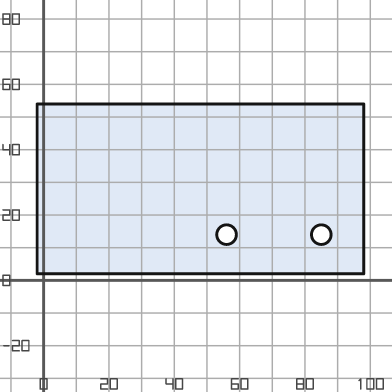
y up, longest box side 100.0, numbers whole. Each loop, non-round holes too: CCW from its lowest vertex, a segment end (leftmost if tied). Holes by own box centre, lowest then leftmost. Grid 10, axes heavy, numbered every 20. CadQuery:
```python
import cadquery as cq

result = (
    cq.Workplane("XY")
    .moveTo(-2.0, 2.0)
    .lineTo(98.0, 2.0)
    .lineTo(98.0, 54.0)
    .lineTo(-2.0, 54.0)
    .close()
    .moveTo(56.0, 14.0)
    .circle(3.0)
    .moveTo(85.0, 14.0)
    .circle(3.0)
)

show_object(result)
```